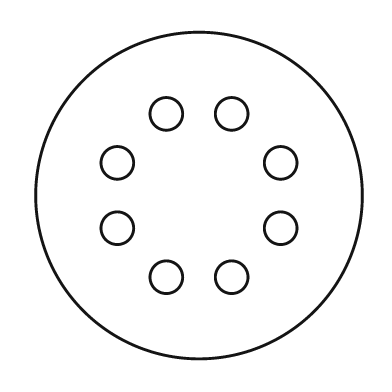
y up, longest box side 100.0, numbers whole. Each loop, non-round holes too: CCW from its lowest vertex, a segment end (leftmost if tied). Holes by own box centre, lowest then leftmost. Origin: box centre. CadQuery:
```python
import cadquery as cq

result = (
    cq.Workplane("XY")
    .moveTo(0.0, 0.0)
    .circle(50.0)
    .moveTo(-10.0, -25.0)
    .circle(5.0)
    .moveTo(10.0, -25.0)
    .circle(5.0)
    .moveTo(-25.0, -10.0)
    .circle(5.0)
    .moveTo(25.0, -10.0)
    .circle(5.0)
    .moveTo(-25.0, 10.0)
    .circle(5.0)
    .moveTo(25.0, 10.0)
    .circle(5.0)
    .moveTo(-10.0, 25.0)
    .circle(5.0)
    .moveTo(10.0, 25.0)
    .circle(5.0)
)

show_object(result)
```